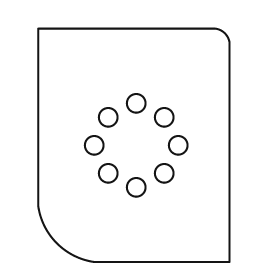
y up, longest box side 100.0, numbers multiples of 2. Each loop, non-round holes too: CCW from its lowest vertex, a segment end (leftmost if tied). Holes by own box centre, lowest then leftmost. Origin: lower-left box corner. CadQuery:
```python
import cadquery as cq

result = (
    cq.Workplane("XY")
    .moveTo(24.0, 0.0)
    .lineTo(82.0, 0.0)
    .lineTo(82.0, 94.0)
    .threePointArc((80.0, 98.0), (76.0, 100.0))
    .lineTo(0.0, 100.0)
    .lineTo(0.0, 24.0)
    .threePointArc((8.0, 8.0), (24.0, 0.0))
    .close()
    .moveTo(42.0, 32.0)
    .circle(4.0)
    .moveTo(30.0, 38.0)
    .circle(4.0)
    .moveTo(54.0, 38.0)
    .circle(4.0)
    .moveTo(24.0, 50.0)
    .circle(4.0)
    .moveTo(60.0, 50.0)
    .circle(4.0)
    .moveTo(30.0, 62.0)
    .circle(4.0)
    .moveTo(54.0, 62.0)
    .circle(4.0)
    .moveTo(42.0, 68.0)
    .circle(4.0)
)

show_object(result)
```